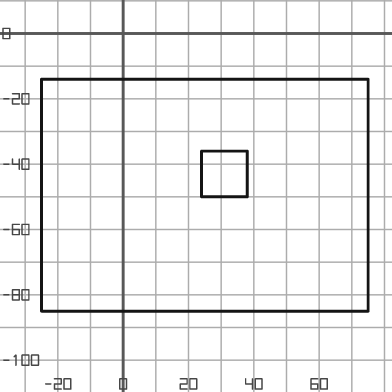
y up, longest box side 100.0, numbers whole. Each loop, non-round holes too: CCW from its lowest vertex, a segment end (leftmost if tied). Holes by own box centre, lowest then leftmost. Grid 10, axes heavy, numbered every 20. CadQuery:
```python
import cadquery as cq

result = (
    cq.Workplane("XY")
    .moveTo(-25.0, -85.0)
    .lineTo(75.0, -85.0)
    .lineTo(75.0, -14.0)
    .lineTo(-25.0, -14.0)
    .close()
    .moveTo(24.0, -50.0)
    .lineTo(38.0, -50.0)
    .lineTo(38.0, -36.0)
    .lineTo(24.0, -36.0)
    .close()
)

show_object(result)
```